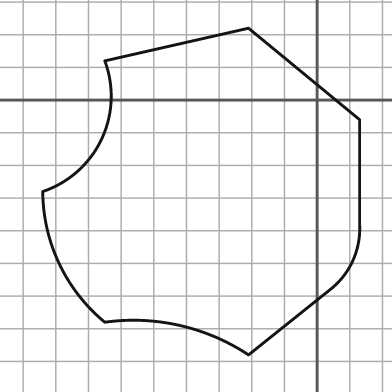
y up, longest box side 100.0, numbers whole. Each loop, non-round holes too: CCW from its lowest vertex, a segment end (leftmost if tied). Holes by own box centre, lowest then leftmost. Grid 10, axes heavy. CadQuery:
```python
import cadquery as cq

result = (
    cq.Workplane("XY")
    .moveTo(-21.0, -78.0)
    .lineTo(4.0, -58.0)
    .threePointArc((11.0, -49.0), (13.0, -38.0))
    .lineTo(13.0, -6.0)
    .lineTo(-21.0, 22.0)
    .lineTo(-65.0, 12.0)
    .threePointArc((-66.0, -12.0), (-84.0, -28.0))
    .threePointArc((-79.0, -50.0), (-65.0, -68.0))
    .threePointArc((-42.0, -69.0), (-21.0, -78.0))
    .close()
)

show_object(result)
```